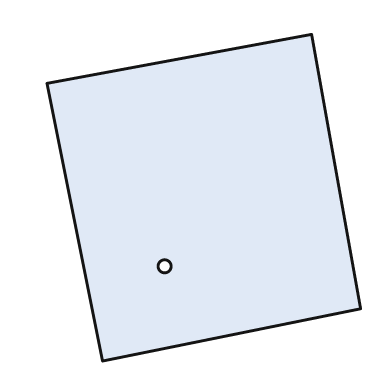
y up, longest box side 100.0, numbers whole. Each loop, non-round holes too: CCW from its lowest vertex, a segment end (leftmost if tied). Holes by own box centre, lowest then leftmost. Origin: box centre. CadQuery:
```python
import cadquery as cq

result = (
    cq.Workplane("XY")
    .moveTo(-31.0, -50.0)
    .lineTo(48.0, -34.0)
    .lineTo(33.0, 50.0)
    .lineTo(-48.0, 35.0)
    .close()
    .moveTo(-12.0, -21.0)
    .circle(2.0)
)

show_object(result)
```